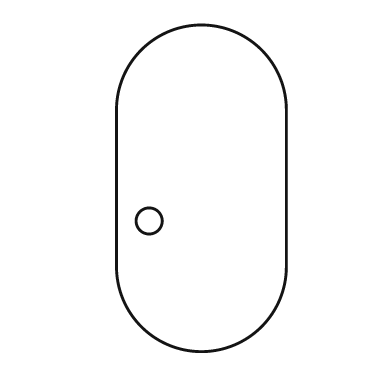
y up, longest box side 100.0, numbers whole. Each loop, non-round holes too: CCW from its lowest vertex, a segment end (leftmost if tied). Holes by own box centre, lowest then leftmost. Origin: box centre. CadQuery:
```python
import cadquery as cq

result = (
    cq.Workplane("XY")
    .moveTo(-26.0, -24.0)
    .threePointArc((0.0, -50.0), (26.0, -24.0))
    .lineTo(26.0, 24.0)
    .threePointArc((0.0, 50.0), (-26.0, 24.0))
    .close()
    .moveTo(-16.0, -10.0)
    .circle(4.0)
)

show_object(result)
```